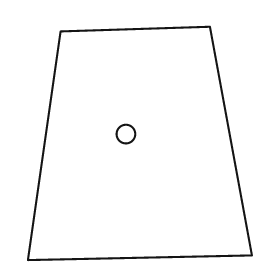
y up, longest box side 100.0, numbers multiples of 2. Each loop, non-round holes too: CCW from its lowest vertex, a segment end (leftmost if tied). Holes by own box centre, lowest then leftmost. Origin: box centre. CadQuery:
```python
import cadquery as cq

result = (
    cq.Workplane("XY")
    .moveTo(-48.0, -50.0)
    .lineTo(48.0, -48.0)
    .lineTo(30.0, 50.0)
    .lineTo(-34.0, 48.0)
    .close()
    .moveTo(-6.0, 4.0)
    .circle(4.0)
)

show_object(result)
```